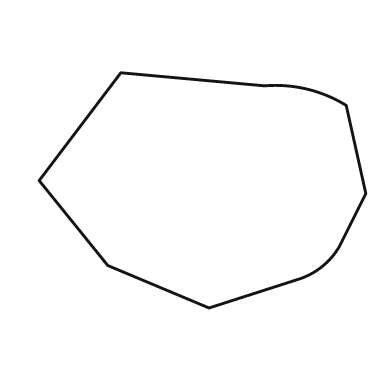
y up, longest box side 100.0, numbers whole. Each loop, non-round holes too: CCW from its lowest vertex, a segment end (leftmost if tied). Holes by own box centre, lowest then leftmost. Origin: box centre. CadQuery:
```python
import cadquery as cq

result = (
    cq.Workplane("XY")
    .moveTo(2.0, -36.0)
    .lineTo(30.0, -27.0)
    .threePointArc((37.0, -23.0), (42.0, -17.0))
    .lineTo(50.0, -1.0)
    .lineTo(44.0, 26.0)
    .threePointArc((32.0, 31.0), (19.0, 32.0))
    .lineTo(-25.0, 36.0)
    .lineTo(-50.0, 3.0)
    .lineTo(-29.0, -23.0)
    .close()
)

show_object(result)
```